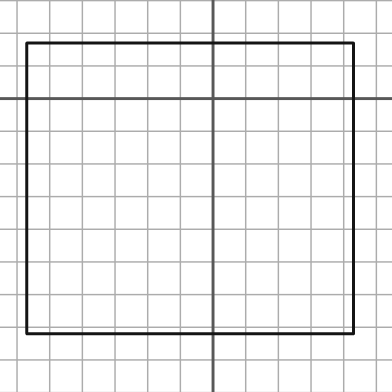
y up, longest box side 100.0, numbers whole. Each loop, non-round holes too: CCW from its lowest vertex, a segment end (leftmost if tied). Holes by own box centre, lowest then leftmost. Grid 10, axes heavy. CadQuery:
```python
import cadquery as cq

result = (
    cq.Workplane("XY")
    .moveTo(-57.0, -72.0)
    .lineTo(43.0, -72.0)
    .lineTo(43.0, 17.0)
    .lineTo(-57.0, 17.0)
    .close()
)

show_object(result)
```